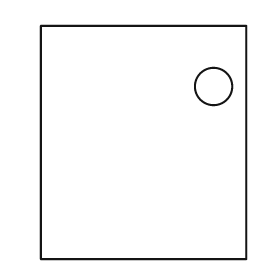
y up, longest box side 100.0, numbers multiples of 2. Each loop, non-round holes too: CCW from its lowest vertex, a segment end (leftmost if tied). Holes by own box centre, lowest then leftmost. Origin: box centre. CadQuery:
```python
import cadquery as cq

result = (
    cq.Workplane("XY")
    .moveTo(-44.0, -50.0)
    .lineTo(44.0, -50.0)
    .lineTo(44.0, 50.0)
    .lineTo(-44.0, 50.0)
    .close()
    .moveTo(30.0, 24.0)
    .circle(8.0)
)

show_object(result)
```